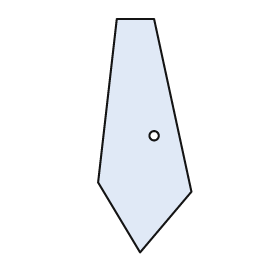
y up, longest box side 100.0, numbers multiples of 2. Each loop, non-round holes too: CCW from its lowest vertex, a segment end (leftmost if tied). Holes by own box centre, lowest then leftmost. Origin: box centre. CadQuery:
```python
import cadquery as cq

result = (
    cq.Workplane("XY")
    .moveTo(-2.0, -50.0)
    .lineTo(20.0, -24.0)
    .lineTo(4.0, 50.0)
    .lineTo(-12.0, 50.0)
    .lineTo(-20.0, -20.0)
    .close()
    .moveTo(4.0, 0.0)
    .circle(2.0)
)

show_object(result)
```